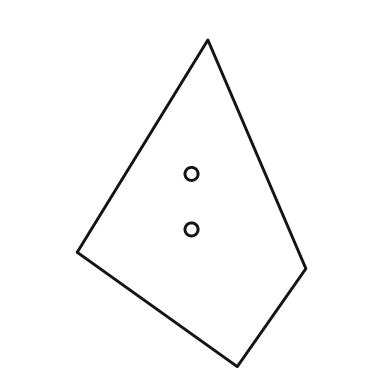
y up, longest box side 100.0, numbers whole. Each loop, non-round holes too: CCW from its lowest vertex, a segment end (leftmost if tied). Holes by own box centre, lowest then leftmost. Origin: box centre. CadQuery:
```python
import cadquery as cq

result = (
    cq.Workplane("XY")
    .moveTo(14.0, -50.0)
    .lineTo(35.0, -20.0)
    .lineTo(5.0, 50.0)
    .lineTo(-35.0, -15.0)
    .close()
    .moveTo(0.0, -8.0)
    .circle(2.0)
    .moveTo(0.0, 9.0)
    .circle(2.0)
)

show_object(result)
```